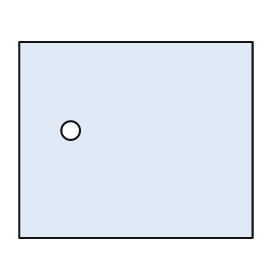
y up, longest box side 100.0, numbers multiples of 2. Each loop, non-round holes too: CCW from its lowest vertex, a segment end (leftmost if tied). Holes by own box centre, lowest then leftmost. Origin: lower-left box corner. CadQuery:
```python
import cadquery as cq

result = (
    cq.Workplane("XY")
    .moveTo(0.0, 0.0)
    .lineTo(100.0, 0.0)
    .lineTo(100.0, 84.0)
    .lineTo(0.0, 84.0)
    .close()
    .moveTo(22.0, 46.0)
    .circle(4.0)
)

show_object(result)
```